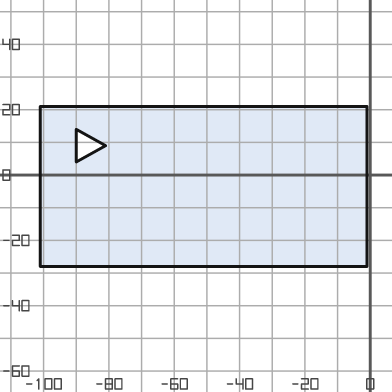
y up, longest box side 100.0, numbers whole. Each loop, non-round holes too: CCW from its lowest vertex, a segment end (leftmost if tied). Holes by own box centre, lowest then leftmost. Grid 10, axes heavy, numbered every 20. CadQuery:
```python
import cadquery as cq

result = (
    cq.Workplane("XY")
    .moveTo(-101.0, -28.0)
    .lineTo(-1.0, -28.0)
    .lineTo(-1.0, 21.0)
    .lineTo(-101.0, 21.0)
    .close()
    .moveTo(-90.0, 4.0)
    .lineTo(-81.0, 9.0)
    .lineTo(-90.0, 14.0)
    .close()
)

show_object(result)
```